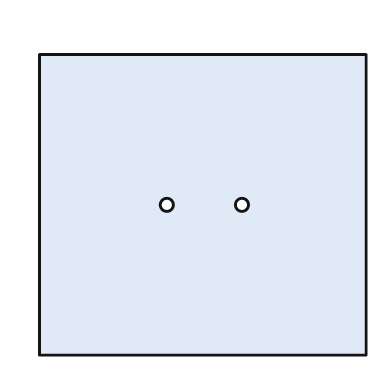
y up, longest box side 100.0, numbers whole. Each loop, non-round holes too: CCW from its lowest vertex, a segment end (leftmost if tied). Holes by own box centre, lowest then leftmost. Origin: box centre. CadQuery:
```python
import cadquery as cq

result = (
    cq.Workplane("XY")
    .moveTo(-50.0, -46.0)
    .lineTo(50.0, -46.0)
    .lineTo(50.0, 46.0)
    .lineTo(-50.0, 46.0)
    .close()
    .moveTo(-11.0, 0.0)
    .circle(2.0)
    .moveTo(12.0, 0.0)
    .circle(2.0)
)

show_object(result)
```